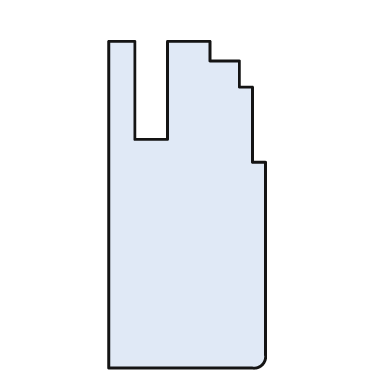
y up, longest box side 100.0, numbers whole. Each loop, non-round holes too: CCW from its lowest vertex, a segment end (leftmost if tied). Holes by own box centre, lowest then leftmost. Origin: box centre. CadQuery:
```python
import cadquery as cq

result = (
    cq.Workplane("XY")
    .moveTo(-24.0, -50.0)
    .lineTo(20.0, -50.0)
    .threePointArc((23.0, -49.0), (24.0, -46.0))
    .lineTo(24.0, 13.0)
    .lineTo(20.0, 13.0)
    .lineTo(20.0, 36.0)
    .lineTo(16.0, 36.0)
    .lineTo(16.0, 44.0)
    .lineTo(7.0, 44.0)
    .lineTo(7.0, 50.0)
    .lineTo(-6.0, 50.0)
    .lineTo(-6.0, 20.0)
    .lineTo(-16.0, 20.0)
    .lineTo(-16.0, 50.0)
    .lineTo(-24.0, 50.0)
    .close()
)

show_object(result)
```